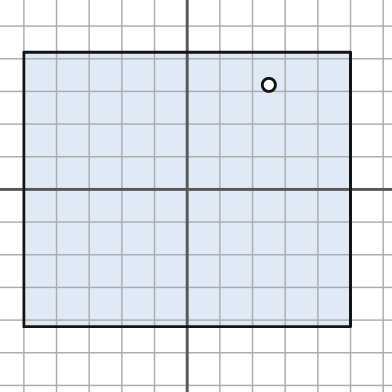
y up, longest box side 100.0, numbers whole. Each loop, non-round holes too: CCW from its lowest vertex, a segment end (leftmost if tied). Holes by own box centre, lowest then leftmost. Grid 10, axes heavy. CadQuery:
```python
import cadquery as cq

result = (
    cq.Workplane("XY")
    .moveTo(-50.0, -42.0)
    .lineTo(50.0, -42.0)
    .lineTo(50.0, 42.0)
    .lineTo(-50.0, 42.0)
    .close()
    .moveTo(25.0, 32.0)
    .circle(2.0)
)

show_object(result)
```